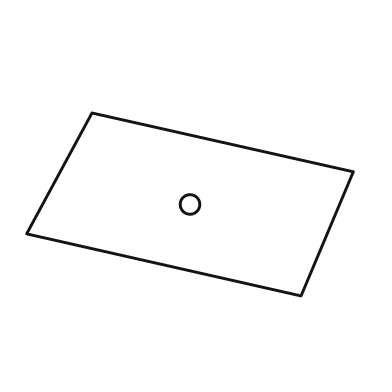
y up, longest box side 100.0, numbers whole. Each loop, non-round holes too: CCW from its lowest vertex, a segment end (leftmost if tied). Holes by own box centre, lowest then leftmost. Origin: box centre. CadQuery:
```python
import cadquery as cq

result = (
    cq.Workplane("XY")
    .moveTo(34.0, -28.0)
    .lineTo(50.0, 10.0)
    .lineTo(-30.0, 28.0)
    .lineTo(-50.0, -9.0)
    .close()
    .moveTo(0.0, 0.0)
    .circle(3.0)
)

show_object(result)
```